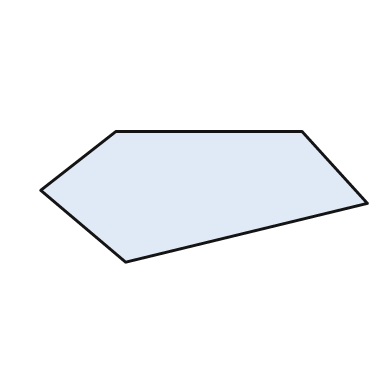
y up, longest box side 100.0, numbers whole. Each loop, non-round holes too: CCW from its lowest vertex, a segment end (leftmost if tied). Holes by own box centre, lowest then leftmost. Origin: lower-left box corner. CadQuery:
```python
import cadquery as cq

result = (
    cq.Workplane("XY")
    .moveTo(26.0, 0.0)
    .lineTo(100.0, 18.0)
    .lineTo(80.0, 40.0)
    .lineTo(23.0, 40.0)
    .lineTo(0.0, 22.0)
    .close()
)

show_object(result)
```